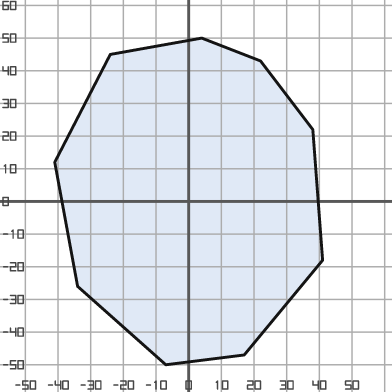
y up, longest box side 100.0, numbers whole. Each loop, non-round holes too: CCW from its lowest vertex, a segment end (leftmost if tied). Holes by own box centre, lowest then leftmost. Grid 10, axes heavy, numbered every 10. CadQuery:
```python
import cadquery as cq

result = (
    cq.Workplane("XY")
    .moveTo(-7.0, -50.0)
    .lineTo(17.0, -47.0)
    .lineTo(41.0, -18.0)
    .lineTo(38.0, 22.0)
    .lineTo(22.0, 43.0)
    .lineTo(4.0, 50.0)
    .lineTo(-24.0, 45.0)
    .lineTo(-41.0, 12.0)
    .lineTo(-34.0, -26.0)
    .close()
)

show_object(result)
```